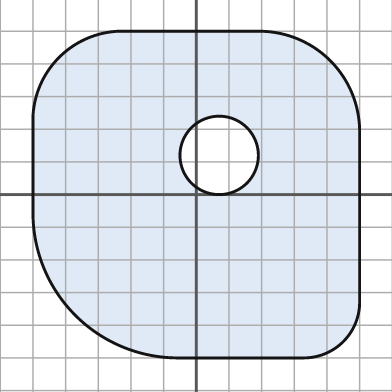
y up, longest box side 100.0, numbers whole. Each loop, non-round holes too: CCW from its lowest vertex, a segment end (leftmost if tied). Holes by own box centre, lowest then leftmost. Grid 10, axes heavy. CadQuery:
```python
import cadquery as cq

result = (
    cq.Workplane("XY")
    .moveTo(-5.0, -50.0)
    .lineTo(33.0, -50.0)
    .threePointArc((45.0, -45.0), (50.0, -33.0))
    .lineTo(50.0, 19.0)
    .threePointArc((41.0, 41.0), (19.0, 50.0))
    .lineTo(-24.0, 50.0)
    .threePointArc((-42.0, 42.0), (-50.0, 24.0))
    .lineTo(-50.0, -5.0)
    .threePointArc((-37.0, -37.0), (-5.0, -50.0))
    .close()
    .moveTo(7.0, 12.0)
    .circle(12.0)
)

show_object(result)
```